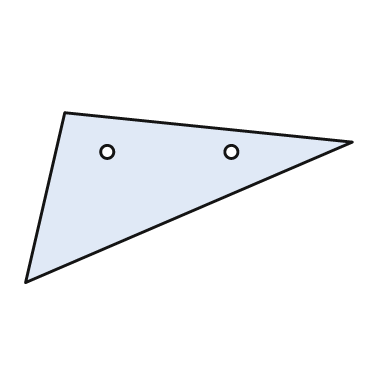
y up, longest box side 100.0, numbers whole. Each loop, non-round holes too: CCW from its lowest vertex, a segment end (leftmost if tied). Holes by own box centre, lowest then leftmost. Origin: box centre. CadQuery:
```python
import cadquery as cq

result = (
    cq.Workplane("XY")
    .moveTo(-50.0, -26.0)
    .lineTo(50.0, 17.0)
    .lineTo(-38.0, 26.0)
    .close()
    .moveTo(-25.0, 14.0)
    .circle(2.0)
    .moveTo(13.0, 14.0)
    .circle(2.0)
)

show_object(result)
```